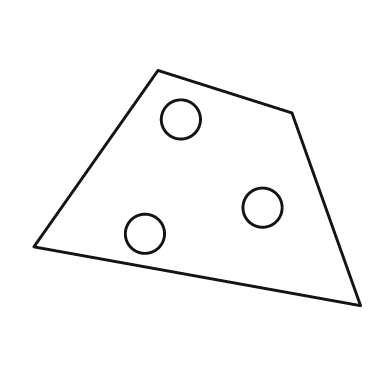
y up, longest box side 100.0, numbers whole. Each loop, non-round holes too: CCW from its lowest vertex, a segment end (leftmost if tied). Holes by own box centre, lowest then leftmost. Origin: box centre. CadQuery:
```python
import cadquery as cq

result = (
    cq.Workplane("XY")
    .moveTo(50.0, -36.0)
    .lineTo(29.0, 23.0)
    .lineTo(-12.0, 36.0)
    .lineTo(-50.0, -18.0)
    .close()
    .moveTo(-16.0, -14.0)
    .circle(6.0)
    .moveTo(20.0, -6.0)
    .circle(6.0)
    .moveTo(-5.0, 21.0)
    .circle(6.0)
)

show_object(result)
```